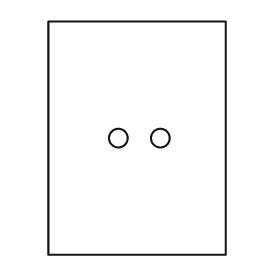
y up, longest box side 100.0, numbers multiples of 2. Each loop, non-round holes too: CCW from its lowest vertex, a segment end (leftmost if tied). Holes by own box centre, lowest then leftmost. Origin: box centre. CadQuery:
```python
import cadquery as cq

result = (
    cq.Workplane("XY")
    .moveTo(-38.0, -50.0)
    .lineTo(38.0, -50.0)
    .lineTo(38.0, 50.0)
    .lineTo(-38.0, 50.0)
    .close()
    .moveTo(-8.0, 0.0)
    .circle(4.0)
    .moveTo(10.0, 0.0)
    .circle(4.0)
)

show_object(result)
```